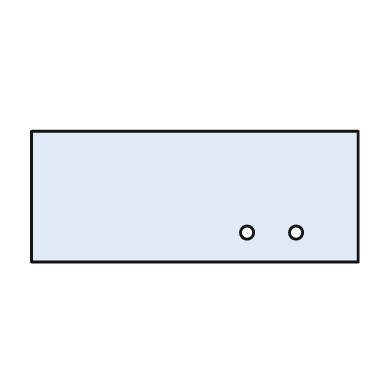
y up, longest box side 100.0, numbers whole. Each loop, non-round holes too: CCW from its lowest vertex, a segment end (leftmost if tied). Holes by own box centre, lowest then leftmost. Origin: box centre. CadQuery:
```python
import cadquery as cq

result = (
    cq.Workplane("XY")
    .moveTo(-50.0, -20.0)
    .lineTo(50.0, -20.0)
    .lineTo(50.0, 20.0)
    .lineTo(-50.0, 20.0)
    .close()
    .moveTo(16.0, -11.0)
    .circle(2.0)
    .moveTo(31.0, -11.0)
    .circle(2.0)
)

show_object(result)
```